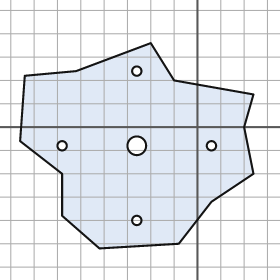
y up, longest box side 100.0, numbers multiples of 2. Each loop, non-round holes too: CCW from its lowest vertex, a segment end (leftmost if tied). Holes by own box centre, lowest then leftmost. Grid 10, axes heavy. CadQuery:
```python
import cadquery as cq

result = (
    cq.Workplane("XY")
    .moveTo(-42.0, -52.0)
    .lineTo(-8.0, -50.0)
    .lineTo(6.0, -32.0)
    .lineTo(24.0, -20.0)
    .lineTo(20.0, 0.0)
    .lineTo(24.0, 14.0)
    .lineTo(-10.0, 20.0)
    .lineTo(-20.0, 36.0)
    .lineTo(-52.0, 24.0)
    .lineTo(-74.0, 22.0)
    .lineTo(-76.0, -6.0)
    .lineTo(-58.0, -20.0)
    .lineTo(-58.0, -38.0)
    .close()
    .moveTo(-26.0, -40.0)
    .circle(2.0)
    .moveTo(-58.0, -8.0)
    .circle(2.0)
    .moveTo(-26.0, -8.0)
    .circle(4.0)
    .moveTo(6.0, -8.0)
    .circle(2.0)
    .moveTo(-26.0, 24.0)
    .circle(2.0)
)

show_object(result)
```